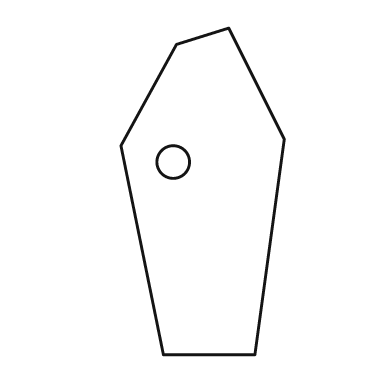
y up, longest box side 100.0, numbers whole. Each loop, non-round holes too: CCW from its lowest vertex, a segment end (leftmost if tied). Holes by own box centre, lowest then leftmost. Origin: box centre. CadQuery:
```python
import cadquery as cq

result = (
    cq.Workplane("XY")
    .moveTo(-12.0, -50.0)
    .lineTo(16.0, -50.0)
    .lineTo(25.0, 16.0)
    .lineTo(8.0, 50.0)
    .lineTo(-8.0, 45.0)
    .lineTo(-25.0, 14.0)
    .close()
    .moveTo(-9.0, 9.0)
    .circle(5.0)
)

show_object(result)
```